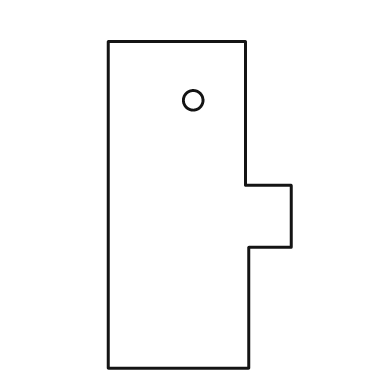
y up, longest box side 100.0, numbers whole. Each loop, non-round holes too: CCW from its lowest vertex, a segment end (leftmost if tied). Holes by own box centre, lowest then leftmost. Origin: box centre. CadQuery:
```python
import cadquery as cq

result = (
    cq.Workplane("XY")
    .moveTo(-28.0, -50.0)
    .lineTo(15.0, -50.0)
    .lineTo(15.0, -13.0)
    .lineTo(28.0, -13.0)
    .lineTo(28.0, 6.0)
    .lineTo(14.0, 6.0)
    .lineTo(14.0, 50.0)
    .lineTo(-28.0, 50.0)
    .close()
    .moveTo(-2.0, 32.0)
    .circle(3.0)
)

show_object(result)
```